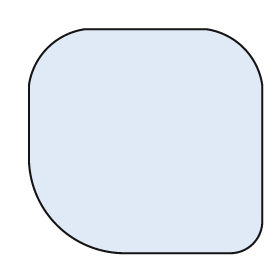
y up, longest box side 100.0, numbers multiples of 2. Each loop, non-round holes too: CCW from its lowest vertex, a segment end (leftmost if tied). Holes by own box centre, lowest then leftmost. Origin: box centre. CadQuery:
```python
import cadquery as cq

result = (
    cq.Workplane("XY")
    .moveTo(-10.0, -48.0)
    .lineTo(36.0, -48.0)
    .threePointArc((46.0, -44.0), (50.0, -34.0))
    .lineTo(50.0, 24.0)
    .threePointArc((42.0, 40.0), (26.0, 48.0))
    .lineTo(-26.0, 48.0)
    .threePointArc((-42.0, 40.0), (-50.0, 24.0))
    .lineTo(-50.0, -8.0)
    .threePointArc((-38.0, -36.0), (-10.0, -48.0))
    .close()
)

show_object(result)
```